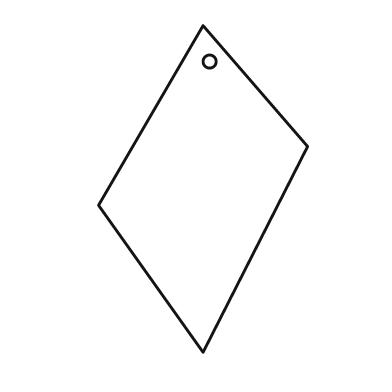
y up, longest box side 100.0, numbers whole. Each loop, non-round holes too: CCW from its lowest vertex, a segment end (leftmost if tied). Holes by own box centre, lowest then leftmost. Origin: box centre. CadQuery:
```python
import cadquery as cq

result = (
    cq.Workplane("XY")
    .moveTo(0.0, -50.0)
    .lineTo(32.0, 13.0)
    .lineTo(0.0, 50.0)
    .lineTo(-32.0, -5.0)
    .close()
    .moveTo(2.0, 39.0)
    .circle(2.0)
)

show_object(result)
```